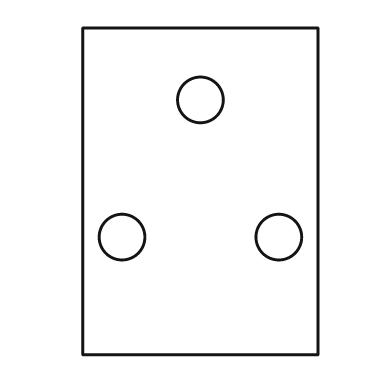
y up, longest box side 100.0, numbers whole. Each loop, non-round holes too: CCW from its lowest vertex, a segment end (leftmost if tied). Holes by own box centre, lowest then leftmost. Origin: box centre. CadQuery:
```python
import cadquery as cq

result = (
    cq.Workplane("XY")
    .moveTo(-36.0, -50.0)
    .lineTo(36.0, -50.0)
    .lineTo(36.0, 50.0)
    .lineTo(-36.0, 50.0)
    .close()
    .moveTo(-24.0, -14.0)
    .circle(7.0)
    .moveTo(24.0, -14.0)
    .circle(7.0)
    .moveTo(0.0, 28.0)
    .circle(7.0)
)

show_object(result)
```